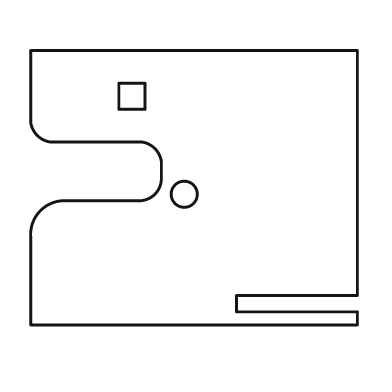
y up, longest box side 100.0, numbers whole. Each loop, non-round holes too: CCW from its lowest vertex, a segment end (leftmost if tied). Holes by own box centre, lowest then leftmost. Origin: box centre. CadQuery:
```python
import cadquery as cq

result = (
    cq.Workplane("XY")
    .moveTo(-50.0, -42.0)
    .lineTo(50.0, -42.0)
    .lineTo(50.0, -38.0)
    .lineTo(13.0, -38.0)
    .lineTo(13.0, -33.0)
    .lineTo(50.0, -33.0)
    .lineTo(50.0, 42.0)
    .lineTo(-50.0, 42.0)
    .lineTo(-50.0, 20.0)
    .threePointArc((-48.0, 16.0), (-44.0, 14.0))
    .lineTo(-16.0, 14.0)
    .threePointArc((-12.0, 12.0), (-10.0, 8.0))
    .lineTo(-10.0, 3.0)
    .threePointArc((-12.0, -2.0), (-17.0, -4.0))
    .lineTo(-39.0, -4.0)
    .threePointArc((-47.0, -7.0), (-50.0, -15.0))
    .close()
    .moveTo(-3.0, -2.0)
    .circle(4.0)
    .moveTo(-23.0, 24.0)
    .lineTo(-15.0, 24.0)
    .lineTo(-15.0, 32.0)
    .lineTo(-23.0, 32.0)
    .close()
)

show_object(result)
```